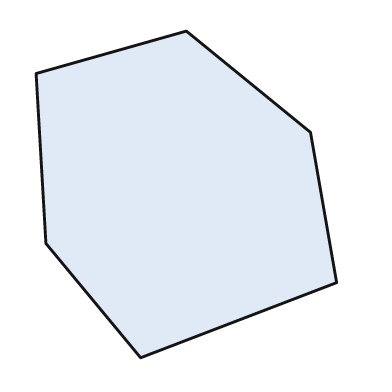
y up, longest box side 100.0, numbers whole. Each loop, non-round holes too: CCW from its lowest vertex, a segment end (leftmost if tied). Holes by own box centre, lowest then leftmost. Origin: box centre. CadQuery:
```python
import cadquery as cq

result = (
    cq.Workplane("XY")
    .moveTo(-14.0, -50.0)
    .lineTo(46.0, -27.0)
    .lineTo(38.0, 19.0)
    .lineTo(0.0, 50.0)
    .lineTo(-46.0, 37.0)
    .lineTo(-43.0, -15.0)
    .close()
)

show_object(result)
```